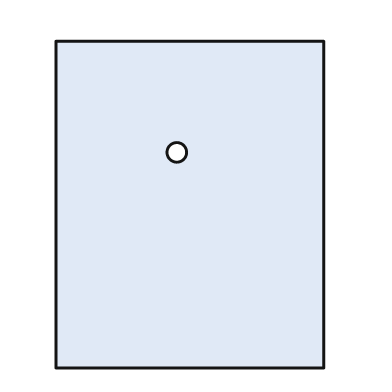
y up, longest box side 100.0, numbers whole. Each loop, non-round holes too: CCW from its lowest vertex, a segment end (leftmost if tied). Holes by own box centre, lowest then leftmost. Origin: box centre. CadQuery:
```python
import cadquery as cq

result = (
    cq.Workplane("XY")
    .moveTo(-41.0, -50.0)
    .lineTo(41.0, -50.0)
    .lineTo(41.0, 50.0)
    .lineTo(-41.0, 50.0)
    .close()
    .moveTo(-4.0, 16.0)
    .circle(3.0)
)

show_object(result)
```